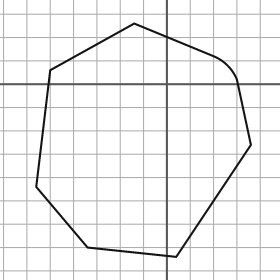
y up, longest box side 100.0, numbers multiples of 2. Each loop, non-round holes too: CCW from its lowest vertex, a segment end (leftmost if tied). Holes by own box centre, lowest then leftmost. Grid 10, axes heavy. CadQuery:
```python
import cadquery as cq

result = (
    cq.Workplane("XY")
    .moveTo(4.0, -74.0)
    .lineTo(36.0, -26.0)
    .lineTo(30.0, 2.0)
    .threePointArc((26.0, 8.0), (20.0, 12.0))
    .lineTo(-14.0, 26.0)
    .lineTo(-50.0, 6.0)
    .lineTo(-56.0, -44.0)
    .lineTo(-34.0, -70.0)
    .close()
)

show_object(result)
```